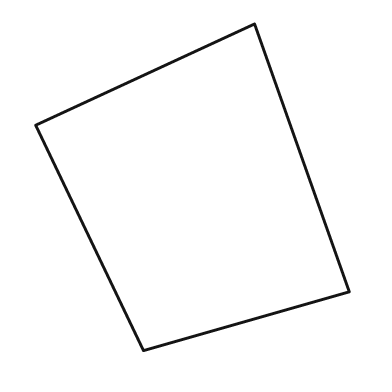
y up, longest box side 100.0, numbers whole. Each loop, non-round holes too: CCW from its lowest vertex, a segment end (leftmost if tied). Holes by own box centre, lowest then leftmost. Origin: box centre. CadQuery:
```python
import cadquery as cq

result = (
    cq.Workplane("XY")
    .moveTo(-15.0, -50.0)
    .lineTo(48.0, -32.0)
    .lineTo(19.0, 50.0)
    .lineTo(-48.0, 19.0)
    .close()
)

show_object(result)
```